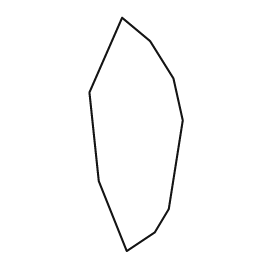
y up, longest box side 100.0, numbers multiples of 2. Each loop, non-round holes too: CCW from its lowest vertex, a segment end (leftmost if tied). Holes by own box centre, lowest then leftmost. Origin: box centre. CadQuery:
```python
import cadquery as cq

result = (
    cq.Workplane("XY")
    .moveTo(-4.0, -50.0)
    .lineTo(8.0, -42.0)
    .lineTo(14.0, -32.0)
    .lineTo(20.0, 6.0)
    .lineTo(16.0, 24.0)
    .lineTo(6.0, 40.0)
    .lineTo(-6.0, 50.0)
    .lineTo(-20.0, 18.0)
    .lineTo(-16.0, -20.0)
    .close()
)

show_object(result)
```